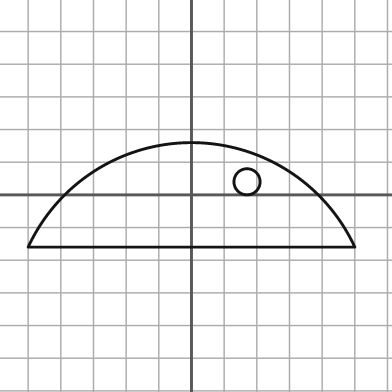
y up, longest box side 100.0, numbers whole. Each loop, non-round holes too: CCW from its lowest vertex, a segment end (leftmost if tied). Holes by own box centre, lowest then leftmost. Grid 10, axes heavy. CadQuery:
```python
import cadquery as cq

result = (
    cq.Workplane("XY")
    .moveTo(-50.0, -16.0)
    .lineTo(50.0, -16.0)
    .threePointArc((0.0, 16.0), (-50.0, -16.0))
    .close()
    .moveTo(17.0, 4.0)
    .circle(4.0)
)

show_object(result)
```